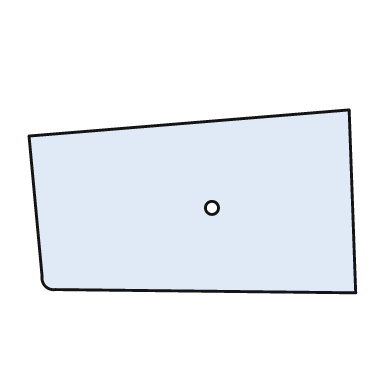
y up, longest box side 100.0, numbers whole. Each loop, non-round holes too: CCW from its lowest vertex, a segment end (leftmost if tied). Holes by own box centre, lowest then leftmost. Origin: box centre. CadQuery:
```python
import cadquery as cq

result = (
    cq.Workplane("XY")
    .moveTo(50.0, -28.0)
    .lineTo(48.0, 28.0)
    .lineTo(-50.0, 20.0)
    .lineTo(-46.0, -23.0)
    .threePointArc((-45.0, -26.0), (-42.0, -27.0))
    .close()
    .moveTo(6.0, -2.0)
    .circle(2.0)
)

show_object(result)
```